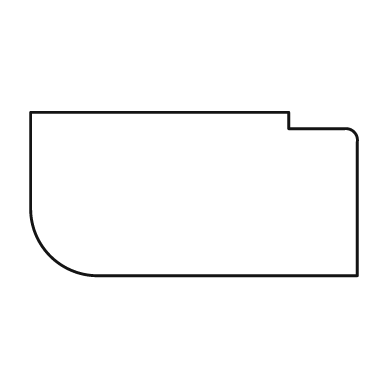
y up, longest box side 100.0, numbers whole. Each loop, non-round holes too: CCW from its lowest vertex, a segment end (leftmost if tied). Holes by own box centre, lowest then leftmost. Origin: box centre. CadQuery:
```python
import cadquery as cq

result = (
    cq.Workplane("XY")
    .moveTo(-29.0, -25.0)
    .lineTo(50.0, -25.0)
    .lineTo(50.0, 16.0)
    .threePointArc((49.0, 19.0), (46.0, 20.0))
    .lineTo(29.0, 20.0)
    .lineTo(29.0, 25.0)
    .lineTo(-50.0, 25.0)
    .lineTo(-50.0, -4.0)
    .threePointArc((-44.0, -19.0), (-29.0, -25.0))
    .close()
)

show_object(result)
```